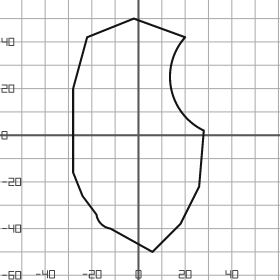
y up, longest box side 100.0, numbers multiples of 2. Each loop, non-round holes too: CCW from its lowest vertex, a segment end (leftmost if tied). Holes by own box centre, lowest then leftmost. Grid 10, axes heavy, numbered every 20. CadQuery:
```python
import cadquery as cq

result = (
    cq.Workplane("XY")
    .moveTo(6.0, -50.0)
    .lineTo(18.0, -38.0)
    .lineTo(26.0, -22.0)
    .lineTo(28.0, 2.0)
    .threePointArc((14.0, 20.0), (20.0, 42.0))
    .lineTo(-2.0, 50.0)
    .lineTo(-22.0, 42.0)
    .lineTo(-28.0, 20.0)
    .lineTo(-28.0, -16.0)
    .lineTo(-24.0, -26.0)
    .lineTo(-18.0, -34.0)
    .threePointArc((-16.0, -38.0), (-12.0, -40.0))
    .close()
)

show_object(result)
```